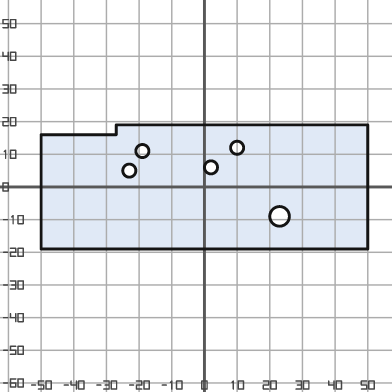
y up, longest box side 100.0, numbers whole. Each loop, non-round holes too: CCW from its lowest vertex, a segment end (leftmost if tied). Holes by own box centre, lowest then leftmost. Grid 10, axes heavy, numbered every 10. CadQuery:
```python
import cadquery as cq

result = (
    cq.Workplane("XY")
    .moveTo(-50.0, -19.0)
    .lineTo(50.0, -19.0)
    .lineTo(50.0, 19.0)
    .lineTo(-27.0, 19.0)
    .lineTo(-27.0, 16.0)
    .lineTo(-50.0, 16.0)
    .close()
    .moveTo(23.0, -9.0)
    .circle(3.0)
    .moveTo(-23.0, 5.0)
    .circle(2.0)
    .moveTo(2.0, 6.0)
    .circle(2.0)
    .moveTo(-19.0, 11.0)
    .circle(2.0)
    .moveTo(10.0, 12.0)
    .circle(2.0)
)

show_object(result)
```